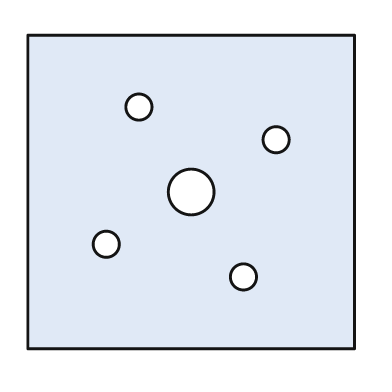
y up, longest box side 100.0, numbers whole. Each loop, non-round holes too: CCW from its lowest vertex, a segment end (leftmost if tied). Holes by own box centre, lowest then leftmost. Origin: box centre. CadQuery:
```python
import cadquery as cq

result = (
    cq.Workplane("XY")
    .moveTo(-50.0, -48.0)
    .lineTo(50.0, -48.0)
    .lineTo(50.0, 48.0)
    .lineTo(-50.0, 48.0)
    .close()
    .moveTo(16.0, -26.0)
    .circle(4.0)
    .moveTo(-26.0, -16.0)
    .circle(4.0)
    .moveTo(0.0, 0.0)
    .circle(7.0)
    .moveTo(26.0, 16.0)
    .circle(4.0)
    .moveTo(-16.0, 26.0)
    .circle(4.0)
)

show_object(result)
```